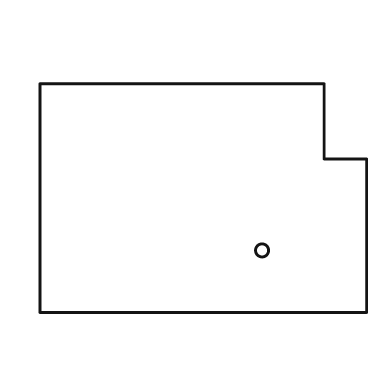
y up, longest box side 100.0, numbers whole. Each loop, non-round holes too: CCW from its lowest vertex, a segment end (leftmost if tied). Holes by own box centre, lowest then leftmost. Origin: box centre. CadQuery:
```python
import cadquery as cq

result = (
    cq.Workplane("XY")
    .moveTo(-50.0, -35.0)
    .lineTo(50.0, -35.0)
    .lineTo(50.0, 12.0)
    .lineTo(37.0, 12.0)
    .lineTo(37.0, 35.0)
    .lineTo(-50.0, 35.0)
    .close()
    .moveTo(18.0, -16.0)
    .circle(2.0)
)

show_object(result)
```